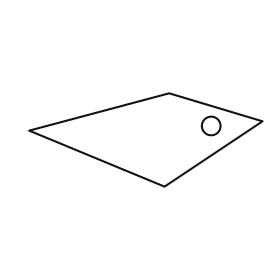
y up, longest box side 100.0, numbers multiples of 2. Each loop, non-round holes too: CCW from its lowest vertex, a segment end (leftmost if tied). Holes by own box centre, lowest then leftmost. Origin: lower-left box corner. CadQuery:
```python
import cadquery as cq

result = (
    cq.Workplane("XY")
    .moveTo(58.0, 0.0)
    .lineTo(100.0, 28.0)
    .lineTo(60.0, 40.0)
    .lineTo(0.0, 24.0)
    .close()
    .moveTo(78.0, 26.0)
    .circle(4.0)
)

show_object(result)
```